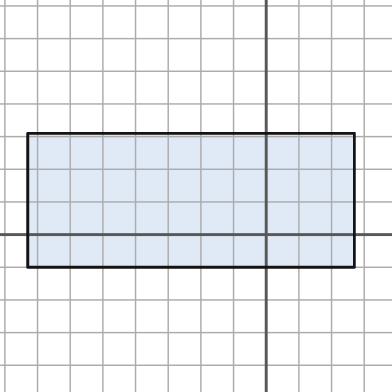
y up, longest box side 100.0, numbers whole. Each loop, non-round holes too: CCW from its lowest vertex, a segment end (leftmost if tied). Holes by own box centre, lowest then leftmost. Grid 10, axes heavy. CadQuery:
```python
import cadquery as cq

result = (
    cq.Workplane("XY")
    .moveTo(-73.0, -10.0)
    .lineTo(27.0, -10.0)
    .lineTo(27.0, 31.0)
    .lineTo(-73.0, 31.0)
    .close()
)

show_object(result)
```